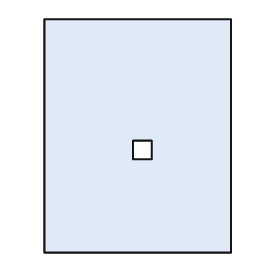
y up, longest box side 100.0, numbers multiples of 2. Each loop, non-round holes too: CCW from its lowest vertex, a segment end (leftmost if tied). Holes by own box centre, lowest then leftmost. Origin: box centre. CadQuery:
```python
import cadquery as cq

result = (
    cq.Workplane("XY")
    .moveTo(-40.0, -50.0)
    .lineTo(40.0, -50.0)
    .lineTo(40.0, 50.0)
    .lineTo(-40.0, 50.0)
    .close()
    .moveTo(-2.0, -10.0)
    .lineTo(6.0, -10.0)
    .lineTo(6.0, -2.0)
    .lineTo(-2.0, -2.0)
    .close()
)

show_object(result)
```